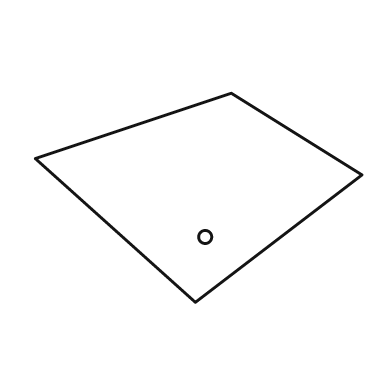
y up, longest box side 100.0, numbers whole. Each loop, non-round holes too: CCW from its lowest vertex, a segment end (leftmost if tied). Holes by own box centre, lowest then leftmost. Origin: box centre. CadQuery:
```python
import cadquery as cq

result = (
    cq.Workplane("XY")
    .moveTo(-1.0, -32.0)
    .lineTo(50.0, 7.0)
    .lineTo(10.0, 32.0)
    .lineTo(-50.0, 12.0)
    .close()
    .moveTo(2.0, -12.0)
    .circle(2.0)
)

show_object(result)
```